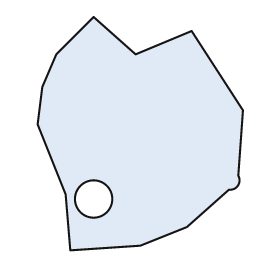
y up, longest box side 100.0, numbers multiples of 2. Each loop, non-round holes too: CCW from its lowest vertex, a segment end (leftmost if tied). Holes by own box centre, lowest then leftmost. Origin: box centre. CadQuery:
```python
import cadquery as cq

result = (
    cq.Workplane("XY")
    .moveTo(-30.0, -50.0)
    .lineTo(0.0, -48.0)
    .lineTo(20.0, -40.0)
    .lineTo(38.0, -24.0)
    .threePointArc((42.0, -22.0), (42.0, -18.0))
    .lineTo(44.0, 10.0)
    .lineTo(22.0, 44.0)
    .lineTo(-2.0, 34.0)
    .lineTo(-20.0, 50.0)
    .lineTo(-36.0, 34.0)
    .lineTo(-42.0, 20.0)
    .lineTo(-44.0, 4.0)
    .lineTo(-32.0, -26.0)
    .close()
    .moveTo(-20.0, -28.0)
    .circle(8.0)
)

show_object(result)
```